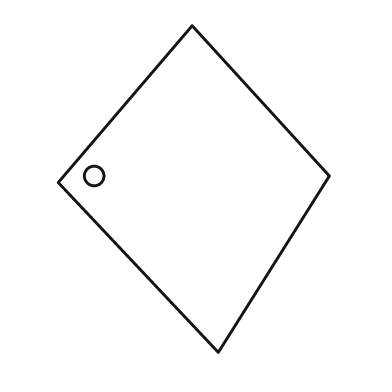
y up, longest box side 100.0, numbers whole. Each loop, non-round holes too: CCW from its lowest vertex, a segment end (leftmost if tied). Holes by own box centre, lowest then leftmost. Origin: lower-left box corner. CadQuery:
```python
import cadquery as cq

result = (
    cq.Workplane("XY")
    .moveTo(49.0, 0.0)
    .lineTo(83.0, 54.0)
    .lineTo(41.0, 100.0)
    .lineTo(0.0, 52.0)
    .close()
    .moveTo(11.0, 54.0)
    .circle(3.0)
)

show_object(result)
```